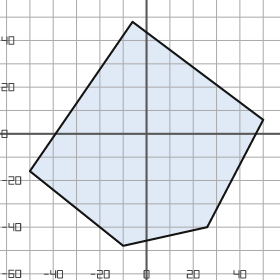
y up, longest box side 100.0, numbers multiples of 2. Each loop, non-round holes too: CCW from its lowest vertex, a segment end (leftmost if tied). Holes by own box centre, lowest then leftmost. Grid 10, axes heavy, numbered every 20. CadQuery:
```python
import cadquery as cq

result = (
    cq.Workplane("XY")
    .moveTo(-10.0, -48.0)
    .lineTo(26.0, -40.0)
    .lineTo(50.0, 6.0)
    .lineTo(-6.0, 48.0)
    .lineTo(-50.0, -16.0)
    .close()
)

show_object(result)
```